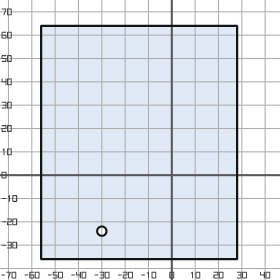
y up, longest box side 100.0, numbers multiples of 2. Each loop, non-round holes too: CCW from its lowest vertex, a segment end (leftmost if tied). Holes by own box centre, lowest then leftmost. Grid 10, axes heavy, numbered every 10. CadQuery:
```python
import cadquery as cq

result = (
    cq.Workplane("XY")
    .moveTo(-56.0, -36.0)
    .lineTo(28.0, -36.0)
    .lineTo(28.0, 64.0)
    .lineTo(-56.0, 64.0)
    .close()
    .moveTo(-30.0, -24.0)
    .circle(2.0)
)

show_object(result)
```